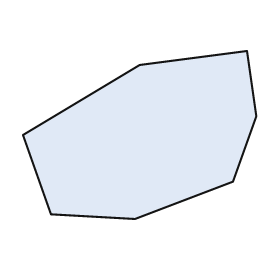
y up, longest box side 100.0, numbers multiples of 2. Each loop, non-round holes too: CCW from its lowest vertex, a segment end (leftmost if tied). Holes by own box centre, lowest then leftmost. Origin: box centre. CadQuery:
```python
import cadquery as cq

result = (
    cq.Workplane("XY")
    .moveTo(-2.0, -36.0)
    .lineTo(40.0, -20.0)
    .lineTo(50.0, 8.0)
    .lineTo(46.0, 36.0)
    .lineTo(0.0, 30.0)
    .lineTo(-50.0, 0.0)
    .lineTo(-38.0, -34.0)
    .close()
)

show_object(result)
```